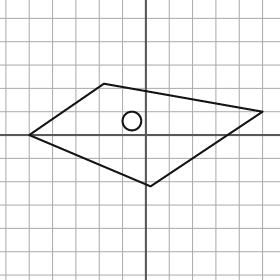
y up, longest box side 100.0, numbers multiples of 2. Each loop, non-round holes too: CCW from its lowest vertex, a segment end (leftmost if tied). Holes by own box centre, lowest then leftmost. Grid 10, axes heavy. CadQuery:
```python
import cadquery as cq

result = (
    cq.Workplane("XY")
    .moveTo(2.0, -22.0)
    .lineTo(50.0, 10.0)
    .lineTo(-18.0, 22.0)
    .lineTo(-50.0, 0.0)
    .close()
    .moveTo(-6.0, 6.0)
    .circle(4.0)
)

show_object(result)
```